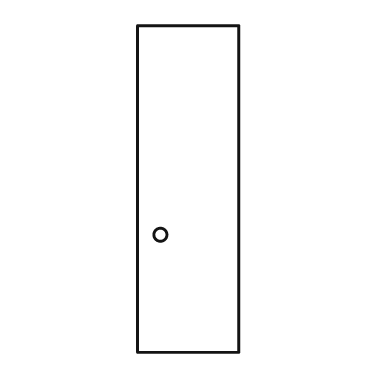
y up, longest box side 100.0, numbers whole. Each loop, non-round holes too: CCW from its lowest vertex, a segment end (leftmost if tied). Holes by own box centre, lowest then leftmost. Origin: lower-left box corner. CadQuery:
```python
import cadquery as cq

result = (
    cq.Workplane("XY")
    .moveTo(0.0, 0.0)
    .lineTo(31.0, 0.0)
    .lineTo(31.0, 100.0)
    .lineTo(0.0, 100.0)
    .close()
    .moveTo(7.0, 36.0)
    .circle(2.0)
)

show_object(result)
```